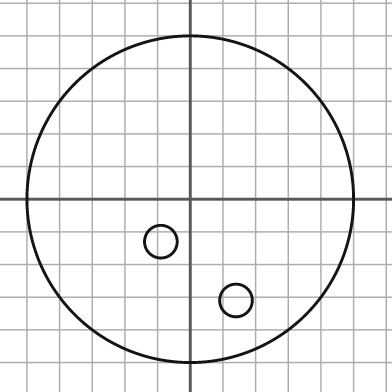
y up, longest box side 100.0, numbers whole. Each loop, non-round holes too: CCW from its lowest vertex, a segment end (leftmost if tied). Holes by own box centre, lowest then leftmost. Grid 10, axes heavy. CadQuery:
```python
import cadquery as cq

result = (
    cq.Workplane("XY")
    .moveTo(0.0, 0.0)
    .circle(50.0)
    .moveTo(14.0, -31.0)
    .circle(5.0)
    .moveTo(-9.0, -13.0)
    .circle(5.0)
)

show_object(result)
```